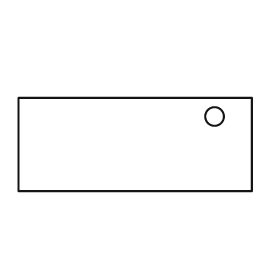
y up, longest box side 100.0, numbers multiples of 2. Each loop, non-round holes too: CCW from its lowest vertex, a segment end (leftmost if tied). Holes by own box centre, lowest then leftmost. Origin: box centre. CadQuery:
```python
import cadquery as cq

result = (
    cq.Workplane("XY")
    .moveTo(-50.0, -20.0)
    .lineTo(50.0, -20.0)
    .lineTo(50.0, 20.0)
    .lineTo(-50.0, 20.0)
    .close()
    .moveTo(34.0, 12.0)
    .circle(4.0)
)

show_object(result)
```